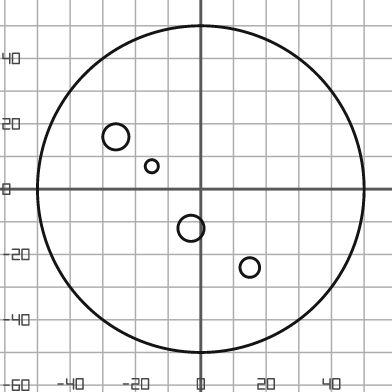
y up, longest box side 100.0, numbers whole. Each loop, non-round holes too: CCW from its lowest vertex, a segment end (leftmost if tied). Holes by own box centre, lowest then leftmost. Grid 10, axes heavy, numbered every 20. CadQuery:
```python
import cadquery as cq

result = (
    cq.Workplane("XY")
    .moveTo(0.0, 0.0)
    .circle(50.0)
    .moveTo(15.0, -24.0)
    .circle(3.0)
    .moveTo(-3.0, -12.0)
    .circle(4.0)
    .moveTo(-15.0, 7.0)
    .circle(2.0)
    .moveTo(-26.0, 16.0)
    .circle(4.0)
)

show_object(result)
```